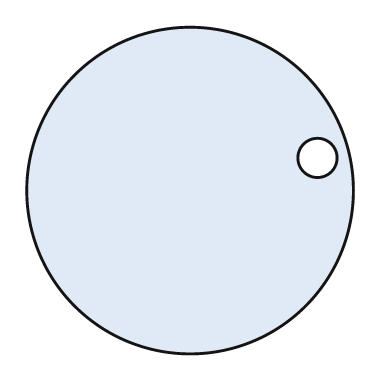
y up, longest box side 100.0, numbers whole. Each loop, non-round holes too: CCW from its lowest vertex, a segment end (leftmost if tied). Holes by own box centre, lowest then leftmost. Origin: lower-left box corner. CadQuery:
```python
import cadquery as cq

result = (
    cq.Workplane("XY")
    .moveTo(50.0, 50.0)
    .circle(50.0)
    .moveTo(89.0, 60.0)
    .circle(6.0)
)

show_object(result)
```